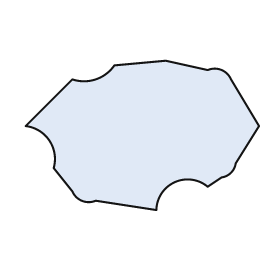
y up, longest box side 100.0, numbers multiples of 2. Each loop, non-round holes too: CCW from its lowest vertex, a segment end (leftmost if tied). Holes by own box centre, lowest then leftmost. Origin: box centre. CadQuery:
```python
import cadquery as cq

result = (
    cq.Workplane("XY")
    .moveTo(6.0, -32.0)
    .threePointArc((14.0, -20.0), (28.0, -22.0))
    .lineTo(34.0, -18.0)
    .threePointArc((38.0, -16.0), (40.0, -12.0))
    .lineTo(50.0, 4.0)
    .lineTo(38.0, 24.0)
    .threePointArc((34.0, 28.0), (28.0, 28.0))
    .lineTo(10.0, 32.0)
    .lineTo(-12.0, 30.0)
    .threePointArc((-20.0, 24.0), (-30.0, 24.0))
    .lineTo(-50.0, 4.0)
    .threePointArc((-40.0, -2.0), (-38.0, -14.0))
    .lineTo(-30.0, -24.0)
    .threePointArc((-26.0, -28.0), (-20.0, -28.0))
    .close()
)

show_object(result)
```